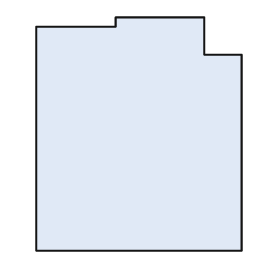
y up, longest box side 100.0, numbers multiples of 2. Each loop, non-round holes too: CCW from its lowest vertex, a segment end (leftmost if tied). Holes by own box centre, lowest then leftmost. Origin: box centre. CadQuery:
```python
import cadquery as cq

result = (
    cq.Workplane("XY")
    .moveTo(-44.0, -50.0)
    .lineTo(44.0, -50.0)
    .lineTo(44.0, 34.0)
    .lineTo(28.0, 34.0)
    .lineTo(28.0, 50.0)
    .lineTo(-10.0, 50.0)
    .lineTo(-10.0, 46.0)
    .lineTo(-44.0, 46.0)
    .close()
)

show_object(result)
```